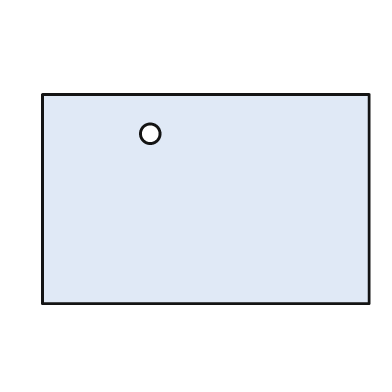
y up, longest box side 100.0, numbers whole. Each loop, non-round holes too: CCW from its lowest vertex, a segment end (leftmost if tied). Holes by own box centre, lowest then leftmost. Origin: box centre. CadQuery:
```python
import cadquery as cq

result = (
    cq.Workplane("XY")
    .moveTo(-50.0, -32.0)
    .lineTo(50.0, -32.0)
    .lineTo(50.0, 32.0)
    .lineTo(-50.0, 32.0)
    .close()
    .moveTo(-17.0, 20.0)
    .circle(3.0)
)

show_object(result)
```